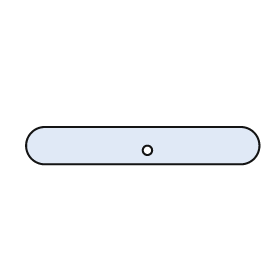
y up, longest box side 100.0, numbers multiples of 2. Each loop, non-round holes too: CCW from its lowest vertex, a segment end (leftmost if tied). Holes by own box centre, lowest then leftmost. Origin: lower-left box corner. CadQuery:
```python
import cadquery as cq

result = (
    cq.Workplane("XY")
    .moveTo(8.0, 0.0)
    .lineTo(92.0, 0.0)
    .threePointArc((100.0, 8.0), (92.0, 16.0))
    .lineTo(8.0, 16.0)
    .threePointArc((0.0, 8.0), (8.0, 0.0))
    .close()
    .moveTo(52.0, 6.0)
    .circle(2.0)
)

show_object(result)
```